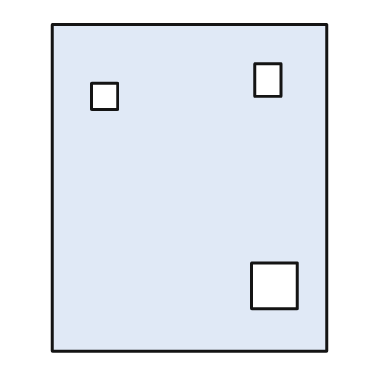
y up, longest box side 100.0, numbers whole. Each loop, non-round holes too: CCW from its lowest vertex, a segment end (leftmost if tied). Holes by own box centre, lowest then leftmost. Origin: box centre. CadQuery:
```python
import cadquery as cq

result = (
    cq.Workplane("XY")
    .moveTo(-42.0, -50.0)
    .lineTo(42.0, -50.0)
    .lineTo(42.0, 50.0)
    .lineTo(-42.0, 50.0)
    .close()
    .moveTo(19.0, -37.0)
    .lineTo(33.0, -37.0)
    .lineTo(33.0, -23.0)
    .lineTo(19.0, -23.0)
    .close()
    .moveTo(-30.0, 24.0)
    .lineTo(-22.0, 24.0)
    .lineTo(-22.0, 32.0)
    .lineTo(-30.0, 32.0)
    .close()
    .moveTo(20.0, 28.0)
    .lineTo(28.0, 28.0)
    .lineTo(28.0, 38.0)
    .lineTo(20.0, 38.0)
    .close()
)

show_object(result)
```